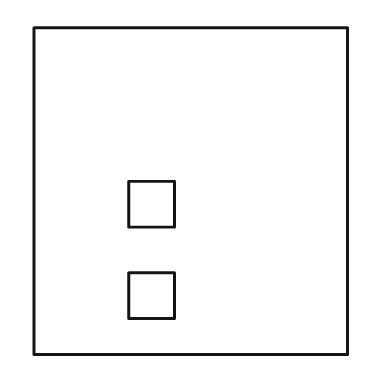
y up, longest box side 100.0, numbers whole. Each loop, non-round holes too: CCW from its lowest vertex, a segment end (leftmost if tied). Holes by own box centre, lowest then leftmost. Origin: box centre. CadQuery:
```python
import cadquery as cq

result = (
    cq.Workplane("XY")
    .moveTo(-48.0, -50.0)
    .lineTo(48.0, -50.0)
    .lineTo(48.0, 50.0)
    .lineTo(-48.0, 50.0)
    .close()
    .moveTo(-19.0, -39.0)
    .lineTo(-5.0, -39.0)
    .lineTo(-5.0, -25.0)
    .lineTo(-19.0, -25.0)
    .close()
    .moveTo(-19.0, -11.0)
    .lineTo(-5.0, -11.0)
    .lineTo(-5.0, 3.0)
    .lineTo(-19.0, 3.0)
    .close()
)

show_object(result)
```